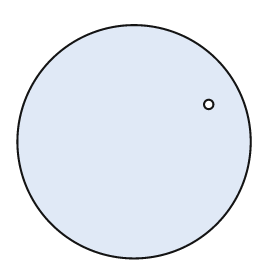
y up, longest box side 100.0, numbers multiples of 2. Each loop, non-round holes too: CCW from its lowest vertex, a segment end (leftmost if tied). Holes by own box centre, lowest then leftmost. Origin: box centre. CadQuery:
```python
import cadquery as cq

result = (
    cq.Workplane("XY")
    .moveTo(0.0, 0.0)
    .circle(50.0)
    .moveTo(32.0, 16.0)
    .circle(2.0)
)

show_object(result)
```